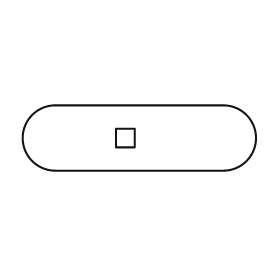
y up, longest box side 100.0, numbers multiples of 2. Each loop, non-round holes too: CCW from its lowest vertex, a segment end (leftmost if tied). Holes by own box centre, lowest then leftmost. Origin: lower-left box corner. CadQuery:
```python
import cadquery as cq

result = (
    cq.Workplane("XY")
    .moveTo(14.0, 0.0)
    .lineTo(86.0, 0.0)
    .threePointArc((100.0, 14.0), (86.0, 28.0))
    .lineTo(14.0, 28.0)
    .threePointArc((0.0, 14.0), (14.0, 0.0))
    .close()
    .moveTo(40.0, 10.0)
    .lineTo(48.0, 10.0)
    .lineTo(48.0, 18.0)
    .lineTo(40.0, 18.0)
    .close()
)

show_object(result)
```